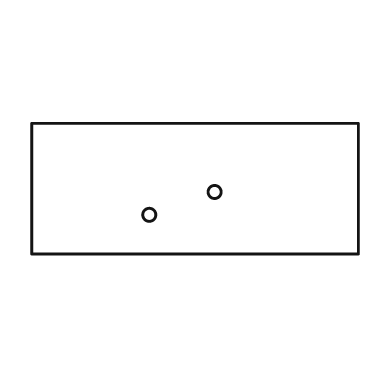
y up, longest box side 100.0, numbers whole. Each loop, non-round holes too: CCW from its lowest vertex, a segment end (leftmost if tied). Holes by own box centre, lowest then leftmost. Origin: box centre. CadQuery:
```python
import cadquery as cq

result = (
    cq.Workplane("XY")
    .moveTo(-50.0, -20.0)
    .lineTo(50.0, -20.0)
    .lineTo(50.0, 20.0)
    .lineTo(-50.0, 20.0)
    .close()
    .moveTo(-14.0, -8.0)
    .circle(2.0)
    .moveTo(6.0, -1.0)
    .circle(2.0)
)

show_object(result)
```